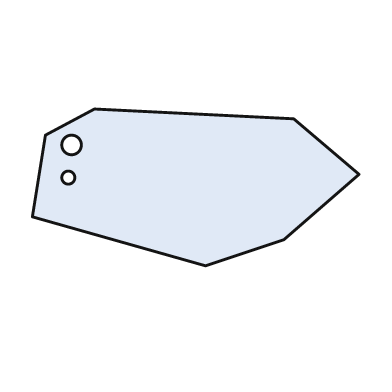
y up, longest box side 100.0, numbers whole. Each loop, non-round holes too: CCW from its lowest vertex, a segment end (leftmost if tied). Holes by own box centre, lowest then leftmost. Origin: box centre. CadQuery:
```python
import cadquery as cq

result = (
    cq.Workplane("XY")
    .moveTo(3.0, -24.0)
    .lineTo(27.0, -16.0)
    .lineTo(50.0, 4.0)
    .lineTo(30.0, 21.0)
    .lineTo(-31.0, 24.0)
    .lineTo(-46.0, 16.0)
    .lineTo(-50.0, -9.0)
    .close()
    .moveTo(-39.0, 3.0)
    .circle(2.0)
    .moveTo(-38.0, 13.0)
    .circle(3.0)
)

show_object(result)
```